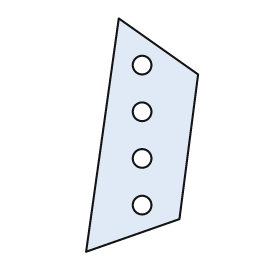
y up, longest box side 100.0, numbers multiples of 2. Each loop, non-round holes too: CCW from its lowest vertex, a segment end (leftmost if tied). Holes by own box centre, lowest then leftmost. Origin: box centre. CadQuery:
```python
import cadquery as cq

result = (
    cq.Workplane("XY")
    .moveTo(-24.0, -50.0)
    .lineTo(16.0, -36.0)
    .lineTo(24.0, 26.0)
    .lineTo(-10.0, 50.0)
    .close()
    .moveTo(0.0, -30.0)
    .circle(4.0)
    .moveTo(0.0, -10.0)
    .circle(4.0)
    .moveTo(0.0, 10.0)
    .circle(4.0)
    .moveTo(0.0, 30.0)
    .circle(4.0)
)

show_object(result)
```